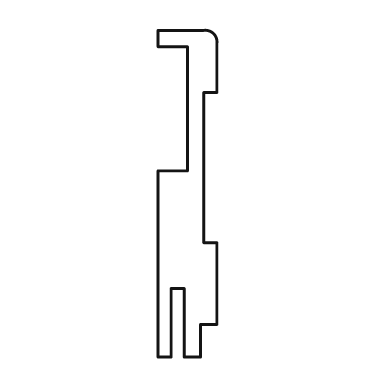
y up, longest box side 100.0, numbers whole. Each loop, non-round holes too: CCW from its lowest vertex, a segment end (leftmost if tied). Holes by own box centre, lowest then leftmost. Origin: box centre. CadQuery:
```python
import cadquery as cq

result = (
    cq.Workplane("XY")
    .moveTo(-9.0, -50.0)
    .lineTo(-5.0, -50.0)
    .lineTo(-5.0, -29.0)
    .lineTo(-1.0, -29.0)
    .lineTo(-1.0, -50.0)
    .lineTo(4.0, -50.0)
    .lineTo(4.0, -40.0)
    .lineTo(9.0, -40.0)
    .lineTo(9.0, -15.0)
    .lineTo(5.0, -15.0)
    .lineTo(5.0, 31.0)
    .lineTo(9.0, 31.0)
    .lineTo(9.0, 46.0)
    .threePointArc((8.0, 49.0), (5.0, 50.0))
    .lineTo(-9.0, 50.0)
    .lineTo(-9.0, 45.0)
    .lineTo(0.0, 45.0)
    .lineTo(0.0, 7.0)
    .lineTo(-9.0, 7.0)
    .close()
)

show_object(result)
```